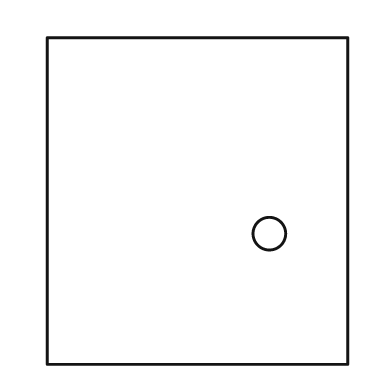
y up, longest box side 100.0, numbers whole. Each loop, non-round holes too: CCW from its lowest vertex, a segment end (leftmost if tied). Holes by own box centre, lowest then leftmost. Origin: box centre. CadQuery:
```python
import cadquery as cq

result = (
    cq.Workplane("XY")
    .moveTo(-46.0, -50.0)
    .lineTo(46.0, -50.0)
    .lineTo(46.0, 50.0)
    .lineTo(-46.0, 50.0)
    .close()
    .moveTo(22.0, -10.0)
    .circle(5.0)
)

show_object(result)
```